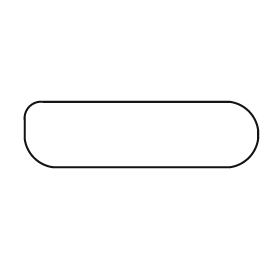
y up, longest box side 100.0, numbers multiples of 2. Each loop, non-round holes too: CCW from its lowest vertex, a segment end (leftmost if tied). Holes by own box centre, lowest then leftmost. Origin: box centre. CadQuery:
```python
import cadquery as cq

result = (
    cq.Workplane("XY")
    .moveTo(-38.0, -14.0)
    .lineTo(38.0, -14.0)
    .threePointArc((46.0, -10.0), (50.0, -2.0))
    .lineTo(50.0, 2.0)
    .threePointArc((46.0, 10.0), (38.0, 14.0))
    .lineTo(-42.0, 14.0)
    .threePointArc((-48.0, 12.0), (-50.0, 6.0))
    .lineTo(-50.0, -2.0)
    .threePointArc((-46.0, -10.0), (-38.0, -14.0))
    .close()
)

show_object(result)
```